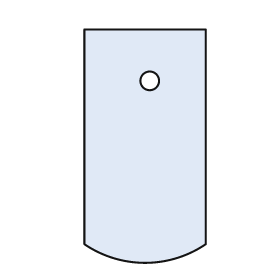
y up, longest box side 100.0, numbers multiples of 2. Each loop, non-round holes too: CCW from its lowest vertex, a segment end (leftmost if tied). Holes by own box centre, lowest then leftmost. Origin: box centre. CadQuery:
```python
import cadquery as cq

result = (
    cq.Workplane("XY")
    .moveTo(-26.0, -42.0)
    .threePointArc((0.0, -50.0), (26.0, -42.0))
    .lineTo(26.0, 50.0)
    .lineTo(-26.0, 50.0)
    .close()
    .moveTo(2.0, 28.0)
    .circle(4.0)
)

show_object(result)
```